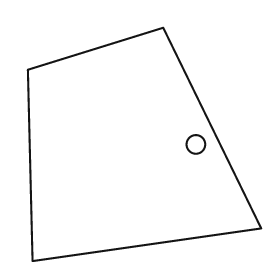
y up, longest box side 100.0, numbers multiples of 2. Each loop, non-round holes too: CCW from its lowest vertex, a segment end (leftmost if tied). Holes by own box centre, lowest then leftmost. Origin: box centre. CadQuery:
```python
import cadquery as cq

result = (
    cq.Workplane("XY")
    .moveTo(-48.0, -50.0)
    .lineTo(50.0, -36.0)
    .lineTo(8.0, 50.0)
    .lineTo(-50.0, 32.0)
    .close()
    .moveTo(22.0, 0.0)
    .circle(4.0)
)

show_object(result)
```